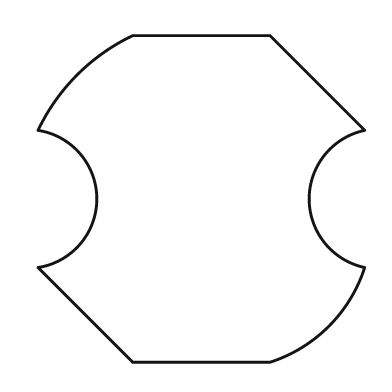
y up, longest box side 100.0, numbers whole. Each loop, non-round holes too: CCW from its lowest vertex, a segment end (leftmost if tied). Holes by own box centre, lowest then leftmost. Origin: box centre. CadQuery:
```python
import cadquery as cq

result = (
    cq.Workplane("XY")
    .moveTo(-21.0, -50.0)
    .lineTo(21.0, -50.0)
    .threePointArc((39.0, -39.0), (50.0, -21.0))
    .threePointArc((33.0, 0.0), (50.0, 21.0))
    .lineTo(21.0, 50.0)
    .lineTo(-21.0, 50.0)
    .threePointArc((-38.0, 38.0), (-50.0, 21.0))
    .threePointArc((-32.0, 0.0), (-50.0, -21.0))
    .close()
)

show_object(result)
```